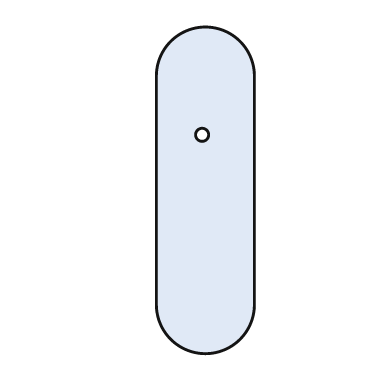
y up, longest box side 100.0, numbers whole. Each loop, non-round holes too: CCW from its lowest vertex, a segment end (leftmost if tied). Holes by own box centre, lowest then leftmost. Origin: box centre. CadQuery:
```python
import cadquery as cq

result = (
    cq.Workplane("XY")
    .moveTo(-15.0, -35.0)
    .threePointArc((0.0, -50.0), (15.0, -35.0))
    .lineTo(15.0, 35.0)
    .threePointArc((0.0, 50.0), (-15.0, 35.0))
    .close()
    .moveTo(-1.0, 17.0)
    .circle(2.0)
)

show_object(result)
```